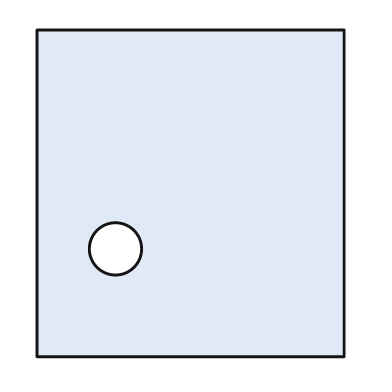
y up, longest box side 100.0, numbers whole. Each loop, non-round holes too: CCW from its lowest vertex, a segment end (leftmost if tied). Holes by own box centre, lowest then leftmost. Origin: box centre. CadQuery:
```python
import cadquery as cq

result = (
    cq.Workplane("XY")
    .moveTo(-47.0, -50.0)
    .lineTo(47.0, -50.0)
    .lineTo(47.0, 50.0)
    .lineTo(-47.0, 50.0)
    .close()
    .moveTo(-23.0, -17.0)
    .circle(8.0)
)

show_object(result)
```